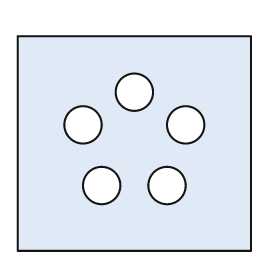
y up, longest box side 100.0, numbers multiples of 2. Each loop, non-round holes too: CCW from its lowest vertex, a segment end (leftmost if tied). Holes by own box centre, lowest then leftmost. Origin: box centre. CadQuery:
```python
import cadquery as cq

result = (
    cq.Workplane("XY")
    .moveTo(-50.0, -46.0)
    .lineTo(50.0, -46.0)
    .lineTo(50.0, 46.0)
    .lineTo(-50.0, 46.0)
    .close()
    .moveTo(-14.0, -18.0)
    .circle(8.0)
    .moveTo(14.0, -18.0)
    .circle(8.0)
    .moveTo(-22.0, 8.0)
    .circle(8.0)
    .moveTo(22.0, 8.0)
    .circle(8.0)
    .moveTo(0.0, 22.0)
    .circle(8.0)
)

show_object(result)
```